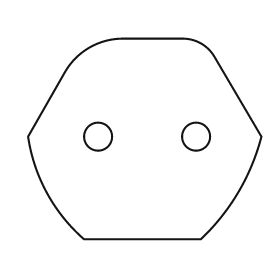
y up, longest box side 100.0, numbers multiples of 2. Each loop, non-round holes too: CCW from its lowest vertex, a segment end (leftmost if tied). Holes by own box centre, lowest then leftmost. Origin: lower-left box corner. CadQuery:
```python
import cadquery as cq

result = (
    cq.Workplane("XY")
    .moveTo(24.0, 0.0)
    .lineTo(74.0, 0.0)
    .threePointArc((90.0, 20.0), (100.0, 44.0))
    .lineTo(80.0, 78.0)
    .threePointArc((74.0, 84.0), (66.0, 86.0))
    .lineTo(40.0, 86.0)
    .threePointArc((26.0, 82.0), (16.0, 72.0))
    .lineTo(0.0, 44.0)
    .threePointArc((8.0, 20.0), (24.0, 0.0))
    .close()
    .moveTo(30.0, 44.0)
    .circle(6.0)
    .moveTo(72.0, 44.0)
    .circle(6.0)
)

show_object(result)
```